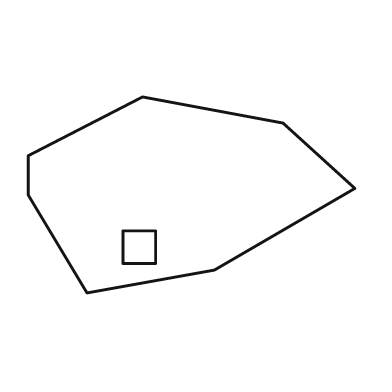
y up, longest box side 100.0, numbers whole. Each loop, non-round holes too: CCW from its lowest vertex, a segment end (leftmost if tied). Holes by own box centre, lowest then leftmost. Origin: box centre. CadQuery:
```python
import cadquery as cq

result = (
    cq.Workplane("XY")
    .moveTo(-32.0, -30.0)
    .lineTo(7.0, -23.0)
    .lineTo(50.0, 2.0)
    .lineTo(28.0, 22.0)
    .lineTo(-15.0, 30.0)
    .lineTo(-50.0, 12.0)
    .lineTo(-50.0, 0.0)
    .close()
    .moveTo(-21.0, -21.0)
    .lineTo(-11.0, -21.0)
    .lineTo(-11.0, -11.0)
    .lineTo(-21.0, -11.0)
    .close()
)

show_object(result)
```